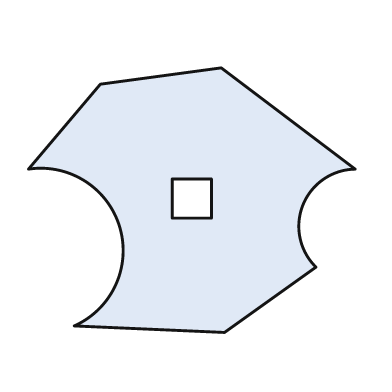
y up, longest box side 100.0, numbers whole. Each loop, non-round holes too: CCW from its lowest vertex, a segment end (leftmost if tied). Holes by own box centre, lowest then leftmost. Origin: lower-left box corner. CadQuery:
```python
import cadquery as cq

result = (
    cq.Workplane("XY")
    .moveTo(60.0, 0.0)
    .lineTo(88.0, 20.0)
    .threePointArc((84.0, 39.0), (100.0, 50.0))
    .lineTo(59.0, 81.0)
    .lineTo(22.0, 76.0)
    .lineTo(0.0, 50.0)
    .threePointArc((28.0, 32.0), (14.0, 2.0))
    .close()
    .moveTo(44.0, 35.0)
    .lineTo(56.0, 35.0)
    .lineTo(56.0, 47.0)
    .lineTo(44.0, 47.0)
    .close()
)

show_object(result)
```